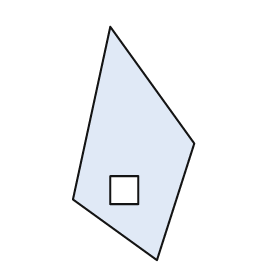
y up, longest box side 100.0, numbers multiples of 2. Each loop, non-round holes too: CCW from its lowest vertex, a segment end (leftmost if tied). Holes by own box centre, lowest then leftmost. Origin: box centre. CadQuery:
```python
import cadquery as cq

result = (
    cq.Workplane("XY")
    .moveTo(10.0, -50.0)
    .lineTo(26.0, 0.0)
    .lineTo(-10.0, 50.0)
    .lineTo(-26.0, -24.0)
    .close()
    .moveTo(-10.0, -26.0)
    .lineTo(2.0, -26.0)
    .lineTo(2.0, -14.0)
    .lineTo(-10.0, -14.0)
    .close()
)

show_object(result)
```